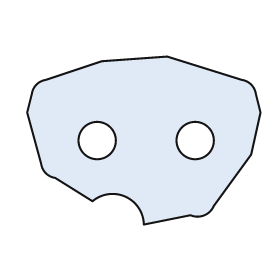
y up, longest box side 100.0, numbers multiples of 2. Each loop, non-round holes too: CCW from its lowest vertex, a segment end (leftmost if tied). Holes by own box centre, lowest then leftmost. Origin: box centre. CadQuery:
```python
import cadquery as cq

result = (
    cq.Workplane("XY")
    .moveTo(0.0, -36.0)
    .lineTo(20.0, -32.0)
    .threePointArc((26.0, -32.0), (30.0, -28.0))
    .lineTo(46.0, -6.0)
    .lineTo(50.0, 12.0)
    .lineTo(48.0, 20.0)
    .threePointArc((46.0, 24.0), (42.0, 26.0))
    .lineTo(10.0, 36.0)
    .lineTo(-18.0, 34.0)
    .lineTo(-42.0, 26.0)
    .threePointArc((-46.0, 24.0), (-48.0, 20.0))
    .lineTo(-50.0, 12.0)
    .lineTo(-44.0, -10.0)
    .threePointArc((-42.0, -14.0), (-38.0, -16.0))
    .lineTo(-22.0, -26.0)
    .threePointArc((-8.0, -24.0), (0.0, -36.0))
    .close()
    .moveTo(-20.0, 0.0)
    .circle(8.0)
    .moveTo(22.0, 0.0)
    .circle(8.0)
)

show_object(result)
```